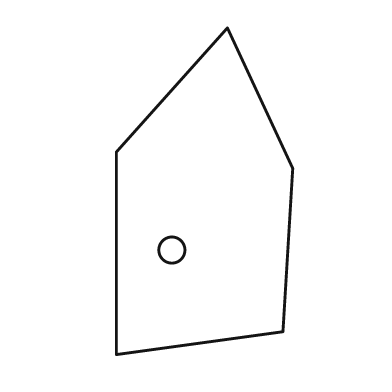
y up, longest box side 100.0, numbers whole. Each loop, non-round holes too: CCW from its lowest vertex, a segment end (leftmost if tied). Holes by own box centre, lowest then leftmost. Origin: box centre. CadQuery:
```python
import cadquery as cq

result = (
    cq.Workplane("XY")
    .moveTo(-27.0, -50.0)
    .lineTo(24.0, -43.0)
    .lineTo(27.0, 7.0)
    .lineTo(7.0, 50.0)
    .lineTo(-27.0, 12.0)
    .close()
    .moveTo(-10.0, -18.0)
    .circle(4.0)
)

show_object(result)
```